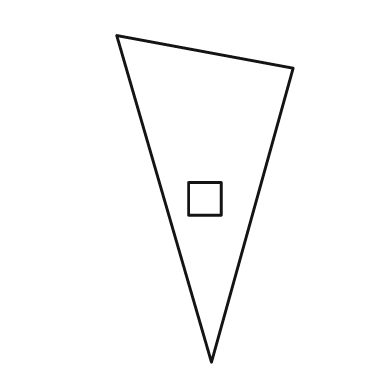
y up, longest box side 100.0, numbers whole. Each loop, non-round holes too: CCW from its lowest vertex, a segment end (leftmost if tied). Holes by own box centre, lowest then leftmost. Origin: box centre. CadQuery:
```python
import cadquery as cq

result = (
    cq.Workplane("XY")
    .moveTo(2.0, -50.0)
    .lineTo(27.0, 40.0)
    .lineTo(-27.0, 50.0)
    .close()
    .moveTo(-5.0, -5.0)
    .lineTo(5.0, -5.0)
    .lineTo(5.0, 5.0)
    .lineTo(-5.0, 5.0)
    .close()
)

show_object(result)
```